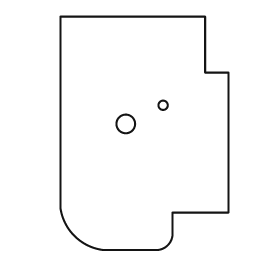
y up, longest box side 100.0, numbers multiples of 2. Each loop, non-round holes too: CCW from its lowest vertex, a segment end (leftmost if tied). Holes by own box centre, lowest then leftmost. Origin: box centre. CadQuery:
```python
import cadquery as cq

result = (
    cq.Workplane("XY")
    .moveTo(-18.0, -50.0)
    .lineTo(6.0, -50.0)
    .threePointArc((10.0, -48.0), (12.0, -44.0))
    .lineTo(12.0, -34.0)
    .lineTo(36.0, -34.0)
    .lineTo(36.0, 26.0)
    .lineTo(26.0, 26.0)
    .lineTo(26.0, 50.0)
    .lineTo(-36.0, 50.0)
    .lineTo(-36.0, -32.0)
    .threePointArc((-30.0, -44.0), (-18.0, -50.0))
    .close()
    .moveTo(-8.0, 4.0)
    .circle(4.0)
    .moveTo(8.0, 12.0)
    .circle(2.0)
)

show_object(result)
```